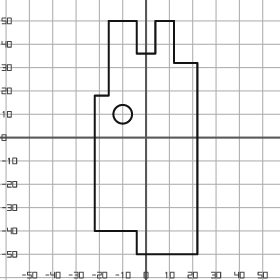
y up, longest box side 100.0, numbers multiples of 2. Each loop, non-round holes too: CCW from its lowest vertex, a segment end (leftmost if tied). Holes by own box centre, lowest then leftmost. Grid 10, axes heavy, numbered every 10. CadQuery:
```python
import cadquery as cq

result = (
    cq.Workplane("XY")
    .moveTo(-4.0, -50.0)
    .lineTo(22.0, -50.0)
    .lineTo(22.0, 32.0)
    .lineTo(12.0, 32.0)
    .lineTo(12.0, 50.0)
    .lineTo(4.0, 50.0)
    .lineTo(4.0, 36.0)
    .lineTo(-4.0, 36.0)
    .lineTo(-4.0, 50.0)
    .lineTo(-16.0, 50.0)
    .lineTo(-16.0, 18.0)
    .lineTo(-22.0, 18.0)
    .lineTo(-22.0, -40.0)
    .lineTo(-4.0, -40.0)
    .close()
    .moveTo(-10.0, 10.0)
    .circle(4.0)
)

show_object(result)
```